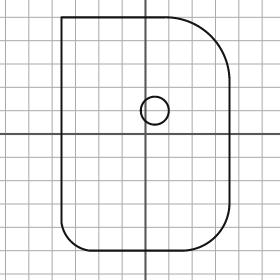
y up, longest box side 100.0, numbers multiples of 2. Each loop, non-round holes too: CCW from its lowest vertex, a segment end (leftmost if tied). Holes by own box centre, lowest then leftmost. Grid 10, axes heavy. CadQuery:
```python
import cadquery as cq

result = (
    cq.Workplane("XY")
    .moveTo(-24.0, -50.0)
    .lineTo(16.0, -50.0)
    .threePointArc((30.0, -44.0), (36.0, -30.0))
    .lineTo(36.0, 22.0)
    .threePointArc((28.0, 42.0), (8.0, 50.0))
    .lineTo(-36.0, 50.0)
    .lineTo(-36.0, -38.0)
    .threePointArc((-32.0, -46.0), (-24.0, -50.0))
    .close()
    .moveTo(4.0, 10.0)
    .circle(6.0)
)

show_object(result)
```